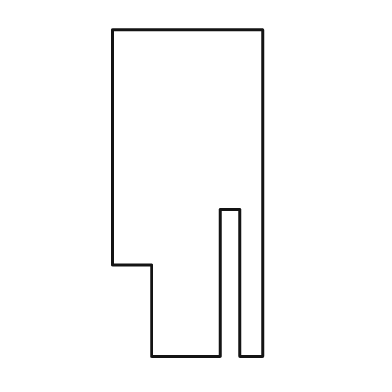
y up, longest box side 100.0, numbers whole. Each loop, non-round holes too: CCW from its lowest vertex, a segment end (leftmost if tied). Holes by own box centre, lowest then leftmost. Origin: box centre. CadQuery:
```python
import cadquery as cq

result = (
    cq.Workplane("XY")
    .moveTo(-11.0, -50.0)
    .lineTo(10.0, -50.0)
    .lineTo(10.0, -5.0)
    .lineTo(16.0, -5.0)
    .lineTo(16.0, -50.0)
    .lineTo(23.0, -50.0)
    .lineTo(23.0, 50.0)
    .lineTo(-23.0, 50.0)
    .lineTo(-23.0, -22.0)
    .lineTo(-11.0, -22.0)
    .close()
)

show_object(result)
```